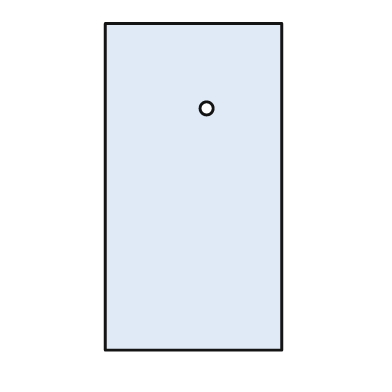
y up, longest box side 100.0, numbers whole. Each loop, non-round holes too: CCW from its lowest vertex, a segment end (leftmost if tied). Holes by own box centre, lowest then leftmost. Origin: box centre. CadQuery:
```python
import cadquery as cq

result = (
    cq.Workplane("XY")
    .moveTo(-27.0, -50.0)
    .lineTo(27.0, -50.0)
    .lineTo(27.0, 50.0)
    .lineTo(-27.0, 50.0)
    .close()
    .moveTo(4.0, 24.0)
    .circle(2.0)
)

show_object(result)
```